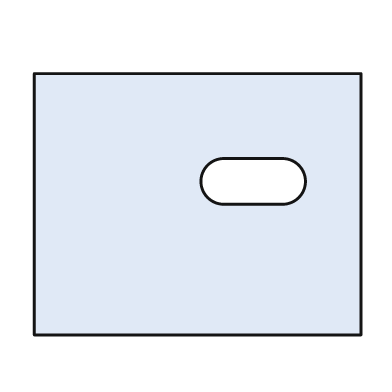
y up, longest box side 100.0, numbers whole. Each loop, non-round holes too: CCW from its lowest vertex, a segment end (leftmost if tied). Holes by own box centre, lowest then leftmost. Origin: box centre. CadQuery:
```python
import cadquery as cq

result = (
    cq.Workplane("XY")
    .moveTo(-50.0, -40.0)
    .lineTo(50.0, -40.0)
    .lineTo(50.0, 40.0)
    .lineTo(-50.0, 40.0)
    .close()
    .moveTo(8.0, 0.0)
    .lineTo(26.0, 0.0)
    .threePointArc((33.0, 7.0), (26.0, 14.0))
    .lineTo(8.0, 14.0)
    .threePointArc((1.0, 7.0), (8.0, 0.0))
    .close()
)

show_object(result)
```